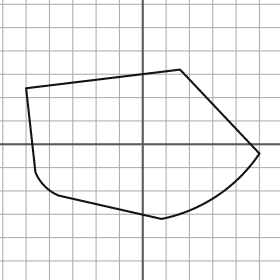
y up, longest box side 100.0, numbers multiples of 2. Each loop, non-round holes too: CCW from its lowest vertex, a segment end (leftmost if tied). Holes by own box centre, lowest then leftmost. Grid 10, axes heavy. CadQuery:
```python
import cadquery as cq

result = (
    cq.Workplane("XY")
    .moveTo(8.0, -32.0)
    .threePointArc((32.0, -22.0), (50.0, -4.0))
    .lineTo(16.0, 32.0)
    .lineTo(-50.0, 24.0)
    .lineTo(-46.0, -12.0)
    .threePointArc((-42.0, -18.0), (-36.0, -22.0))
    .close()
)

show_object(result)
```